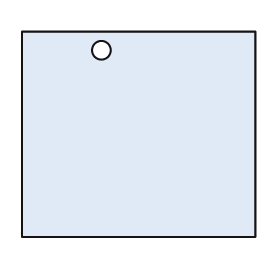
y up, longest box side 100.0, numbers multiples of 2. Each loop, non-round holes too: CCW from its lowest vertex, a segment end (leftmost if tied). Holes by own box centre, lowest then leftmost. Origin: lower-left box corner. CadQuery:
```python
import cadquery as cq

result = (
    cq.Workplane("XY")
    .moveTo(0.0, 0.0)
    .lineTo(100.0, 0.0)
    .lineTo(100.0, 88.0)
    .lineTo(0.0, 88.0)
    .close()
    .moveTo(34.0, 80.0)
    .circle(4.0)
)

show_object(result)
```